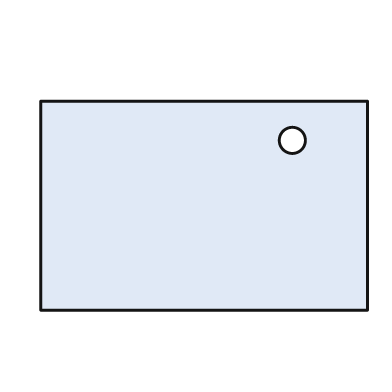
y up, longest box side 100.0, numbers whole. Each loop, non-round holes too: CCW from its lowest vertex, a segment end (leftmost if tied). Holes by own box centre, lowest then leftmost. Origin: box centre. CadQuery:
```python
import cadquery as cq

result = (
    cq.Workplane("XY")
    .moveTo(-50.0, -32.0)
    .lineTo(50.0, -32.0)
    .lineTo(50.0, 32.0)
    .lineTo(-50.0, 32.0)
    .close()
    .moveTo(27.0, 20.0)
    .circle(4.0)
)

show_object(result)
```